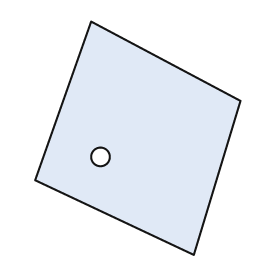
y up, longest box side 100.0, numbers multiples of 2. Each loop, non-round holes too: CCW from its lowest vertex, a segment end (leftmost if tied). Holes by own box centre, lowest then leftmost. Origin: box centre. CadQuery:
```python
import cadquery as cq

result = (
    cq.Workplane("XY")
    .moveTo(24.0, -50.0)
    .lineTo(44.0, 16.0)
    .lineTo(-20.0, 50.0)
    .lineTo(-44.0, -18.0)
    .close()
    .moveTo(-16.0, -8.0)
    .circle(4.0)
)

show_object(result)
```